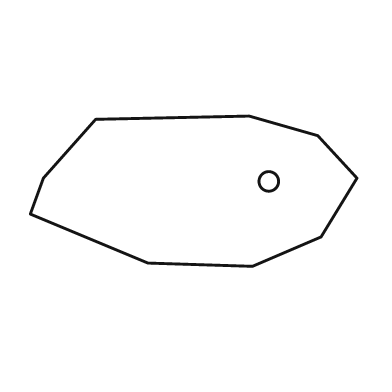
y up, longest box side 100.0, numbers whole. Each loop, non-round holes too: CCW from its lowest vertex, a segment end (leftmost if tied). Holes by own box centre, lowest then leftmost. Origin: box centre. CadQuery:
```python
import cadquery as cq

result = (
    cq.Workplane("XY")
    .moveTo(18.0, -23.0)
    .lineTo(39.0, -14.0)
    .lineTo(50.0, 4.0)
    .lineTo(38.0, 17.0)
    .lineTo(17.0, 23.0)
    .lineTo(-30.0, 22.0)
    .lineTo(-46.0, 4.0)
    .lineTo(-50.0, -7.0)
    .lineTo(-14.0, -22.0)
    .close()
    .moveTo(23.0, 3.0)
    .circle(3.0)
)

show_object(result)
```